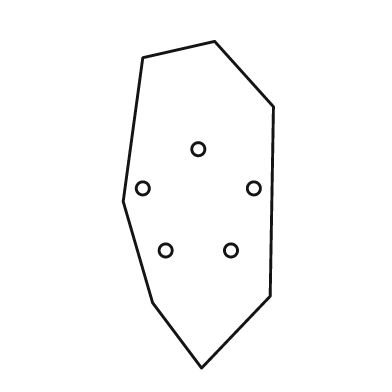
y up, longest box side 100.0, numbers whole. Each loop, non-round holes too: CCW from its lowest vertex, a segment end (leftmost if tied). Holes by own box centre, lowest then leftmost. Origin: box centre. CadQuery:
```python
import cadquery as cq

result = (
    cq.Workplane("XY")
    .moveTo(1.0, -50.0)
    .lineTo(22.0, -28.0)
    .lineTo(23.0, 30.0)
    .lineTo(5.0, 50.0)
    .lineTo(-17.0, 45.0)
    .lineTo(-23.0, 1.0)
    .lineTo(-14.0, -30.0)
    .close()
    .moveTo(-10.0, -14.0)
    .circle(2.0)
    .moveTo(10.0, -14.0)
    .circle(2.0)
    .moveTo(-17.0, 5.0)
    .circle(2.0)
    .moveTo(17.0, 5.0)
    .circle(2.0)
    .moveTo(0.0, 17.0)
    .circle(2.0)
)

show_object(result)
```